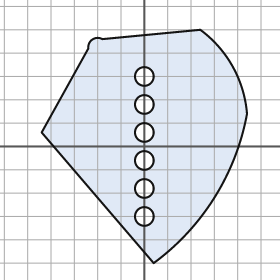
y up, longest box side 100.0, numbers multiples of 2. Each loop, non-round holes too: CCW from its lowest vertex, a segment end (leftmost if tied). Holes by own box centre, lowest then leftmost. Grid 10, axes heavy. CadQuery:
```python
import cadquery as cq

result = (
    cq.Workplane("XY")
    .moveTo(4.0, -50.0)
    .threePointArc((30.0, -22.0), (44.0, 14.0))
    .threePointArc((38.0, 34.0), (24.0, 50.0))
    .lineTo(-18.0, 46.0)
    .threePointArc((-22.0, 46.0), (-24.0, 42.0))
    .lineTo(-44.0, 6.0)
    .close()
    .moveTo(0.0, -30.0)
    .circle(4.0)
    .moveTo(0.0, -18.0)
    .circle(4.0)
    .moveTo(0.0, -6.0)
    .circle(4.0)
    .moveTo(0.0, 6.0)
    .circle(4.0)
    .moveTo(0.0, 18.0)
    .circle(4.0)
    .moveTo(0.0, 30.0)
    .circle(4.0)
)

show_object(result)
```